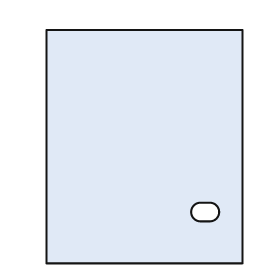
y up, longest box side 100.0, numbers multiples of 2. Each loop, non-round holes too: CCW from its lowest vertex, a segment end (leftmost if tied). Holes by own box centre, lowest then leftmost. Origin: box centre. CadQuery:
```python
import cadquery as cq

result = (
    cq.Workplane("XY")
    .moveTo(-42.0, -50.0)
    .lineTo(42.0, -50.0)
    .lineTo(42.0, 50.0)
    .lineTo(-42.0, 50.0)
    .close()
    .moveTo(24.0, -32.0)
    .lineTo(28.0, -32.0)
    .threePointArc((32.0, -28.0), (28.0, -24.0))
    .lineTo(24.0, -24.0)
    .threePointArc((20.0, -28.0), (24.0, -32.0))
    .close()
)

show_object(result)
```